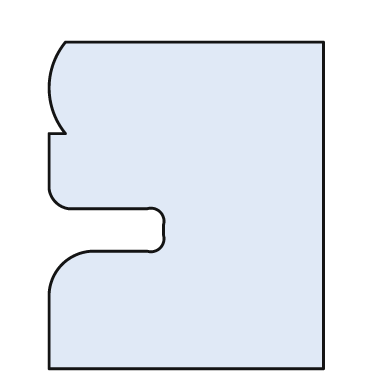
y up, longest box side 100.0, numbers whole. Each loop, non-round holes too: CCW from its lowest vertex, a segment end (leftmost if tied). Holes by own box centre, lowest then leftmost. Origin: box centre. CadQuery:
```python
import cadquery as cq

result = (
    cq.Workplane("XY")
    .moveTo(-42.0, -50.0)
    .lineTo(42.0, -50.0)
    .lineTo(42.0, 50.0)
    .lineTo(-37.0, 50.0)
    .threePointArc((-42.0, 36.0), (-37.0, 22.0))
    .lineTo(-42.0, 22.0)
    .lineTo(-42.0, 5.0)
    .threePointArc((-40.0, 1.0), (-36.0, -1.0))
    .lineTo(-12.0, -1.0)
    .threePointArc((-8.0, -2.0), (-7.0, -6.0))
    .lineTo(-7.0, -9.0)
    .threePointArc((-8.0, -13.0), (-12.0, -14.0))
    .lineTo(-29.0, -14.0)
    .threePointArc((-38.0, -18.0), (-42.0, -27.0))
    .close()
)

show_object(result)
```